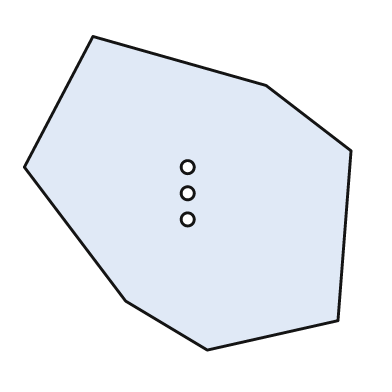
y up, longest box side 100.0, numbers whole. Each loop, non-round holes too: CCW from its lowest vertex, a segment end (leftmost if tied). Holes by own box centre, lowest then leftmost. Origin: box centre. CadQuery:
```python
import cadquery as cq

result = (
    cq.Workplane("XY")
    .moveTo(6.0, -48.0)
    .lineTo(46.0, -39.0)
    .lineTo(50.0, 13.0)
    .lineTo(24.0, 33.0)
    .lineTo(-29.0, 48.0)
    .lineTo(-50.0, 8.0)
    .lineTo(-19.0, -33.0)
    .close()
    .moveTo(0.0, -8.0)
    .circle(2.0)
    .moveTo(0.0, 0.0)
    .circle(2.0)
    .moveTo(0.0, 8.0)
    .circle(2.0)
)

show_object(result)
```